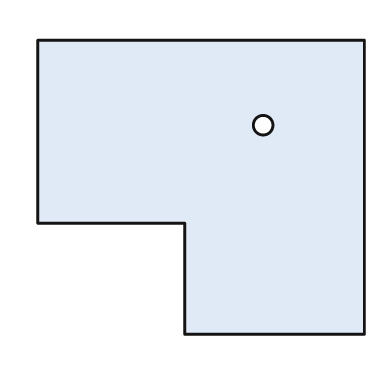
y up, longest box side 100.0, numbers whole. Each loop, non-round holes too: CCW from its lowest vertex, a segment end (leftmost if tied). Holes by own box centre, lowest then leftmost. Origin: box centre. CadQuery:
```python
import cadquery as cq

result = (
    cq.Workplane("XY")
    .moveTo(-5.0, -45.0)
    .lineTo(50.0, -45.0)
    .lineTo(50.0, 45.0)
    .lineTo(-50.0, 45.0)
    .lineTo(-50.0, -11.0)
    .lineTo(-5.0, -11.0)
    .close()
    .moveTo(19.0, 19.0)
    .circle(3.0)
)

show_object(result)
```